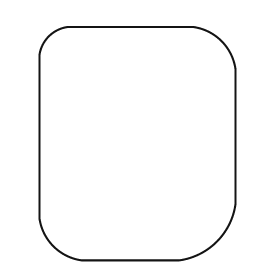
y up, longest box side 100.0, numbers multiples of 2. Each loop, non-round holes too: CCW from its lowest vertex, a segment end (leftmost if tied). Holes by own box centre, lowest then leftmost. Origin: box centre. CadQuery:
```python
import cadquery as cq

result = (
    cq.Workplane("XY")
    .moveTo(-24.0, -50.0)
    .lineTo(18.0, -50.0)
    .threePointArc((34.0, -42.0), (42.0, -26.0))
    .lineTo(42.0, 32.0)
    .threePointArc((36.0, 44.0), (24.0, 50.0))
    .lineTo(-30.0, 50.0)
    .threePointArc((-38.0, 46.0), (-42.0, 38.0))
    .lineTo(-42.0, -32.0)
    .threePointArc((-36.0, -44.0), (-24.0, -50.0))
    .close()
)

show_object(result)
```